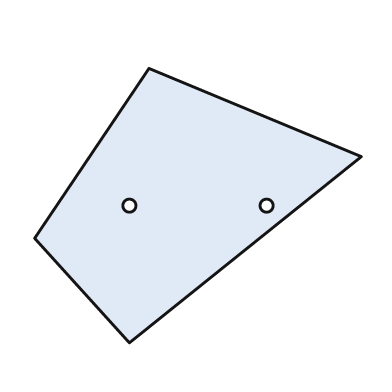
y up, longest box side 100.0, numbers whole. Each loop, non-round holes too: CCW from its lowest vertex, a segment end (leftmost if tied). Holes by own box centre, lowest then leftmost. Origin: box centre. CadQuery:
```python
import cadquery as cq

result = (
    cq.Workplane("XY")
    .moveTo(-21.0, -42.0)
    .lineTo(50.0, 15.0)
    .lineTo(-15.0, 42.0)
    .lineTo(-50.0, -10.0)
    .close()
    .moveTo(-21.0, 0.0)
    .circle(2.0)
    .moveTo(21.0, 0.0)
    .circle(2.0)
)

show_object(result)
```